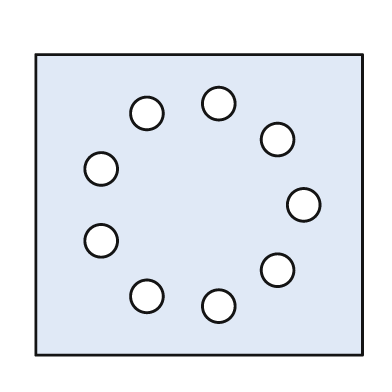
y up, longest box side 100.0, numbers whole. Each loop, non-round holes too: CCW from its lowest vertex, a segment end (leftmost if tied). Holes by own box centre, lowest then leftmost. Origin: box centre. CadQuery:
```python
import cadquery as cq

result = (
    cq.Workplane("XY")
    .moveTo(-50.0, -46.0)
    .lineTo(50.0, -46.0)
    .lineTo(50.0, 46.0)
    .lineTo(-50.0, 46.0)
    .close()
    .moveTo(6.0, -31.0)
    .circle(5.0)
    .moveTo(-16.0, -28.0)
    .circle(5.0)
    .moveTo(24.0, -20.0)
    .circle(5.0)
    .moveTo(-30.0, -11.0)
    .circle(5.0)
    .moveTo(32.0, 0.0)
    .circle(5.0)
    .moveTo(-30.0, 11.0)
    .circle(5.0)
    .moveTo(24.0, 20.0)
    .circle(5.0)
    .moveTo(-16.0, 28.0)
    .circle(5.0)
    .moveTo(6.0, 31.0)
    .circle(5.0)
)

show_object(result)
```